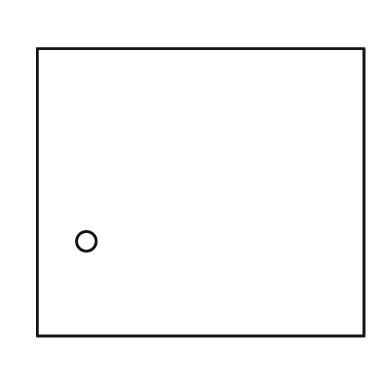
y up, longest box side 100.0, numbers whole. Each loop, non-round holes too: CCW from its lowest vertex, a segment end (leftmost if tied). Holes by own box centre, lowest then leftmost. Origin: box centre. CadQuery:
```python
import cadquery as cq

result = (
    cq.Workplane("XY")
    .moveTo(-50.0, -44.0)
    .lineTo(50.0, -44.0)
    .lineTo(50.0, 44.0)
    .lineTo(-50.0, 44.0)
    .close()
    .moveTo(-35.0, -15.0)
    .circle(3.0)
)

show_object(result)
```